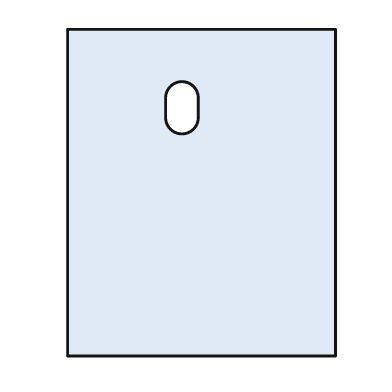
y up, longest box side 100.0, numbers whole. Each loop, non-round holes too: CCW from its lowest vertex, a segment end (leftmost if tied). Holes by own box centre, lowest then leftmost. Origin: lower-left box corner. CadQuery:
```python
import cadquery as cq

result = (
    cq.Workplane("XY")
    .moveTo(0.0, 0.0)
    .lineTo(82.0, 0.0)
    .lineTo(82.0, 100.0)
    .lineTo(0.0, 100.0)
    .close()
    .moveTo(30.0, 73.0)
    .threePointArc((35.0, 68.0), (40.0, 73.0))
    .lineTo(40.0, 79.0)
    .threePointArc((35.0, 84.0), (30.0, 79.0))
    .close()
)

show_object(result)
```